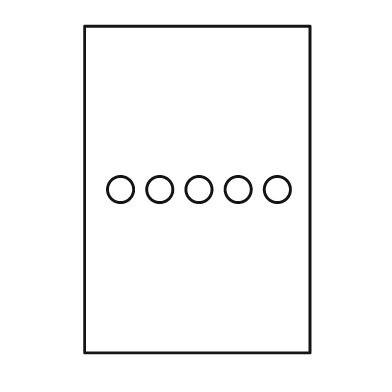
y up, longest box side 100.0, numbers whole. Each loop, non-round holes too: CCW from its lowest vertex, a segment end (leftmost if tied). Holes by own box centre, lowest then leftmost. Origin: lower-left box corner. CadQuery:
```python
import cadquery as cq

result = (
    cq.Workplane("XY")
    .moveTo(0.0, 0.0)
    .lineTo(69.0, 0.0)
    .lineTo(69.0, 100.0)
    .lineTo(0.0, 100.0)
    .close()
    .moveTo(11.0, 50.0)
    .circle(4.0)
    .moveTo(23.0, 50.0)
    .circle(4.0)
    .moveTo(35.0, 50.0)
    .circle(4.0)
    .moveTo(47.0, 50.0)
    .circle(4.0)
    .moveTo(59.0, 50.0)
    .circle(4.0)
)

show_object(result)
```